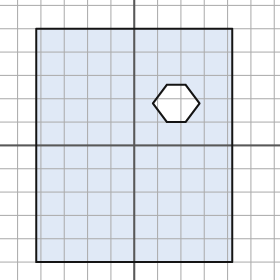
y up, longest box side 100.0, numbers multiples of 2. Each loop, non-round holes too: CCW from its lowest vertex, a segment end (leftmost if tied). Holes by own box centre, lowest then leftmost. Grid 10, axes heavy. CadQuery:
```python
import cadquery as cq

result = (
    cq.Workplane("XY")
    .moveTo(-42.0, -50.0)
    .lineTo(42.0, -50.0)
    .lineTo(42.0, 50.0)
    .lineTo(-42.0, 50.0)
    .close()
    .moveTo(14.0, 10.0)
    .lineTo(22.0, 10.0)
    .lineTo(28.0, 18.0)
    .lineTo(22.0, 26.0)
    .lineTo(14.0, 26.0)
    .lineTo(8.0, 18.0)
    .close()
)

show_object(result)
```